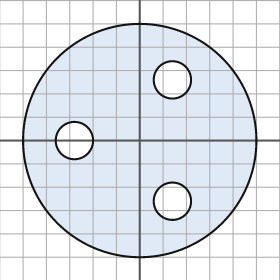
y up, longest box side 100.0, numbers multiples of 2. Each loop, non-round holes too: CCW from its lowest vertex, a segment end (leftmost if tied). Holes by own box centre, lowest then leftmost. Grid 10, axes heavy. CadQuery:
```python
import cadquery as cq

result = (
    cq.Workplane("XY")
    .moveTo(0.0, 0.0)
    .circle(50.0)
    .moveTo(14.0, -26.0)
    .circle(8.0)
    .moveTo(-28.0, 0.0)
    .circle(8.0)
    .moveTo(14.0, 26.0)
    .circle(8.0)
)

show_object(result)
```